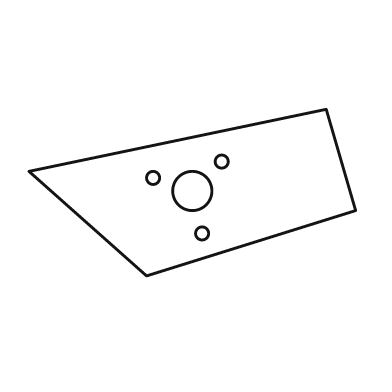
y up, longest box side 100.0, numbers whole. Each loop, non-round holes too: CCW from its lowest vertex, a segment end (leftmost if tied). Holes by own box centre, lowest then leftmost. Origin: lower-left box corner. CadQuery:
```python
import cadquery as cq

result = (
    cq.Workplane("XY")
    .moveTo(36.0, 0.0)
    .lineTo(100.0, 20.0)
    .lineTo(91.0, 51.0)
    .lineTo(0.0, 32.0)
    .close()
    .moveTo(53.0, 13.0)
    .circle(2.0)
    .moveTo(50.0, 26.0)
    .circle(6.0)
    .moveTo(38.0, 30.0)
    .circle(2.0)
    .moveTo(59.0, 35.0)
    .circle(2.0)
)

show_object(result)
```